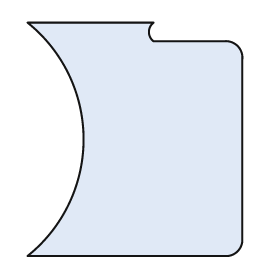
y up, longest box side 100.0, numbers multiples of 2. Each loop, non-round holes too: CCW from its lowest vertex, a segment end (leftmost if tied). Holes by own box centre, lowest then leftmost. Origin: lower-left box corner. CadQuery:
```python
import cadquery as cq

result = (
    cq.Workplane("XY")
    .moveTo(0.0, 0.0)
    .lineTo(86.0, 0.0)
    .threePointArc((90.0, 2.0), (92.0, 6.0))
    .lineTo(92.0, 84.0)
    .threePointArc((90.0, 90.0), (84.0, 92.0))
    .lineTo(54.0, 92.0)
    .threePointArc((52.0, 96.0), (54.0, 100.0))
    .lineTo(0.0, 100.0)
    .threePointArc((24.0, 50.0), (0.0, 0.0))
    .close()
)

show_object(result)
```